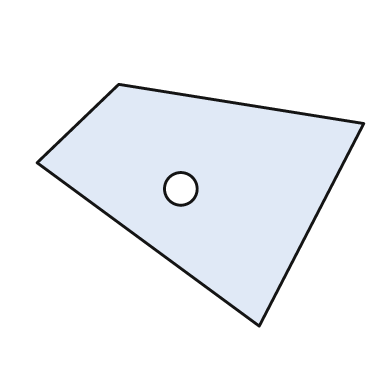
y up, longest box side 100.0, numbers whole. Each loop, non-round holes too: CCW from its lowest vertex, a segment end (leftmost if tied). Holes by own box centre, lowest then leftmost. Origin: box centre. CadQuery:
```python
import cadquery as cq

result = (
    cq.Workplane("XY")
    .moveTo(18.0, -37.0)
    .lineTo(50.0, 25.0)
    .lineTo(-25.0, 37.0)
    .lineTo(-50.0, 13.0)
    .close()
    .moveTo(-6.0, 5.0)
    .circle(5.0)
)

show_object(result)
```